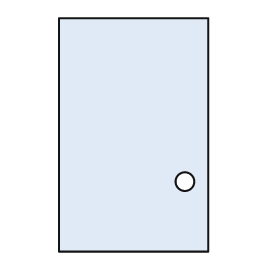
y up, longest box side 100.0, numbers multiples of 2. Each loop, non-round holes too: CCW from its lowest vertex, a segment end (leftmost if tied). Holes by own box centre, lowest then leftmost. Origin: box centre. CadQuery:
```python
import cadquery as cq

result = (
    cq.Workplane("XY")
    .moveTo(-32.0, -50.0)
    .lineTo(32.0, -50.0)
    .lineTo(32.0, 50.0)
    .lineTo(-32.0, 50.0)
    .close()
    .moveTo(22.0, -20.0)
    .circle(4.0)
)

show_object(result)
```